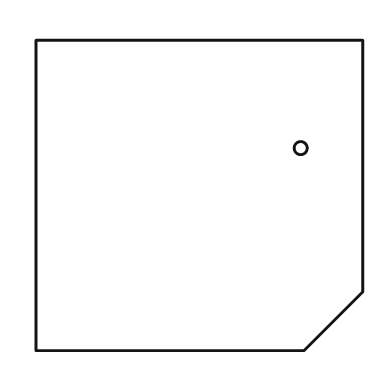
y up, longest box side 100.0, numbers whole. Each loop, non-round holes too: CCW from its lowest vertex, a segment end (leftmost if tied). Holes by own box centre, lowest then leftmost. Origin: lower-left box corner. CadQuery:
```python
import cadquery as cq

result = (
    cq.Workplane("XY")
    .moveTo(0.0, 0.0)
    .lineTo(82.0, 0.0)
    .lineTo(100.0, 18.0)
    .lineTo(100.0, 95.0)
    .lineTo(0.0, 95.0)
    .close()
    .moveTo(81.0, 62.0)
    .circle(2.0)
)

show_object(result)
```